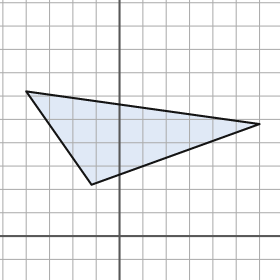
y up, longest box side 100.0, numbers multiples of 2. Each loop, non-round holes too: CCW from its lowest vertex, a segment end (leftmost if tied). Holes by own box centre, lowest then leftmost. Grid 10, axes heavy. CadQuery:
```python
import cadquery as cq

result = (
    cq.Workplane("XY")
    .moveTo(-12.0, 22.0)
    .lineTo(60.0, 48.0)
    .lineTo(-40.0, 62.0)
    .close()
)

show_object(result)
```